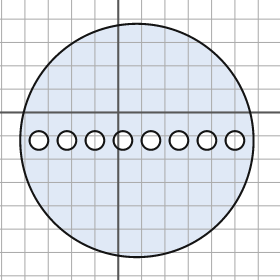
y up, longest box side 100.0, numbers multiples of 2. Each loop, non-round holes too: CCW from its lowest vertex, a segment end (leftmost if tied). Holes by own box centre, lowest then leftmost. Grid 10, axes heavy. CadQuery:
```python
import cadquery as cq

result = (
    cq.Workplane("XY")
    .moveTo(8.0, -12.0)
    .circle(50.0)
    .moveTo(-34.0, -12.0)
    .circle(4.0)
    .moveTo(-22.0, -12.0)
    .circle(4.0)
    .moveTo(-10.0, -12.0)
    .circle(4.0)
    .moveTo(2.0, -12.0)
    .circle(4.0)
    .moveTo(14.0, -12.0)
    .circle(4.0)
    .moveTo(26.0, -12.0)
    .circle(4.0)
    .moveTo(38.0, -12.0)
    .circle(4.0)
    .moveTo(50.0, -12.0)
    .circle(4.0)
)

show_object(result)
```